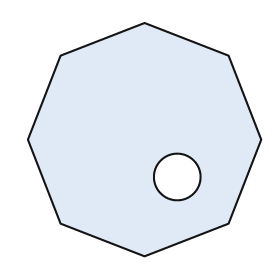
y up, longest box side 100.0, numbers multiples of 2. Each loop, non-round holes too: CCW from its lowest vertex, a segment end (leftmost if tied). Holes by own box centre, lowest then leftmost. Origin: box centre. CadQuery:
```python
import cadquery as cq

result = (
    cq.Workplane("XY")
    .moveTo(0.0, -50.0)
    .lineTo(36.0, -36.0)
    .lineTo(50.0, 0.0)
    .lineTo(36.0, 36.0)
    .lineTo(0.0, 50.0)
    .lineTo(-36.0, 36.0)
    .lineTo(-50.0, 0.0)
    .lineTo(-36.0, -36.0)
    .close()
    .moveTo(14.0, -16.0)
    .circle(10.0)
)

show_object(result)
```